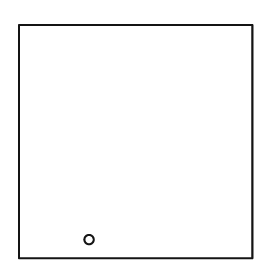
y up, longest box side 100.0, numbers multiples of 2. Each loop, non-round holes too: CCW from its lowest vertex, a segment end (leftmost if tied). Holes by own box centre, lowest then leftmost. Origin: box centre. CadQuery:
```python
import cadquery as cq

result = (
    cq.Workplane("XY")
    .moveTo(-50.0, -50.0)
    .lineTo(50.0, -50.0)
    .lineTo(50.0, 50.0)
    .lineTo(-50.0, 50.0)
    .close()
    .moveTo(-20.0, -42.0)
    .circle(2.0)
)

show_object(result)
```